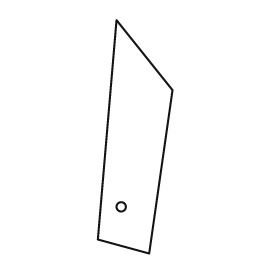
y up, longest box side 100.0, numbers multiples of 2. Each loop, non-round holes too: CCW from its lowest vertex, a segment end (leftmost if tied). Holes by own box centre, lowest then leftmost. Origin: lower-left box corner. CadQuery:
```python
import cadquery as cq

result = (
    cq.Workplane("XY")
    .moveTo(22.0, 0.0)
    .lineTo(32.0, 70.0)
    .lineTo(8.0, 100.0)
    .lineTo(0.0, 6.0)
    .close()
    .moveTo(10.0, 20.0)
    .circle(2.0)
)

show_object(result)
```